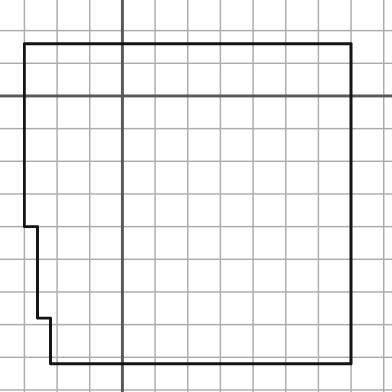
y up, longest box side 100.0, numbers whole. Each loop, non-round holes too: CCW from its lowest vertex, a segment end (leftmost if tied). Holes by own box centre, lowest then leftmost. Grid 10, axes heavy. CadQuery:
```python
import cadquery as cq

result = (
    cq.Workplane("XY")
    .moveTo(-22.0, -82.0)
    .lineTo(70.0, -82.0)
    .lineTo(70.0, 16.0)
    .lineTo(-30.0, 16.0)
    .lineTo(-30.0, -40.0)
    .lineTo(-26.0, -40.0)
    .lineTo(-26.0, -68.0)
    .lineTo(-22.0, -68.0)
    .close()
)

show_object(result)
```